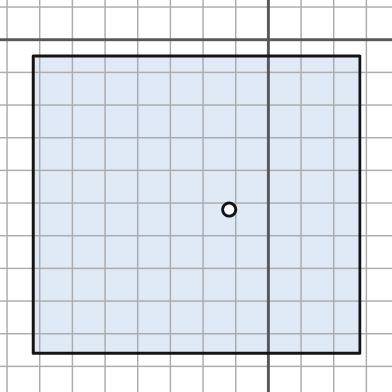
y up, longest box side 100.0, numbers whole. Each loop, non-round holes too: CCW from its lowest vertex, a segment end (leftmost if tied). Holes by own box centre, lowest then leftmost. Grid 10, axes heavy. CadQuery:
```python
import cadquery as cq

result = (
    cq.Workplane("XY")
    .moveTo(-72.0, -96.0)
    .lineTo(28.0, -96.0)
    .lineTo(28.0, -5.0)
    .lineTo(-72.0, -5.0)
    .close()
    .moveTo(-12.0, -52.0)
    .circle(2.0)
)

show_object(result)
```